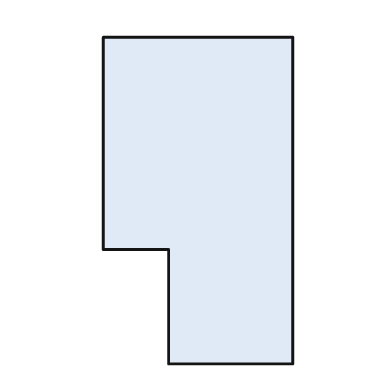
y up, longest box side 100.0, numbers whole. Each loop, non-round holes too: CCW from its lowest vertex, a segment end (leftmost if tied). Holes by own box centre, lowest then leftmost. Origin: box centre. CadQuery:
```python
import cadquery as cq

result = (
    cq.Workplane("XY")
    .moveTo(-9.0, -50.0)
    .lineTo(29.0, -50.0)
    .lineTo(29.0, 50.0)
    .lineTo(-29.0, 50.0)
    .lineTo(-29.0, -15.0)
    .lineTo(-9.0, -15.0)
    .close()
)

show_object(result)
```